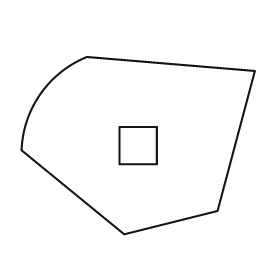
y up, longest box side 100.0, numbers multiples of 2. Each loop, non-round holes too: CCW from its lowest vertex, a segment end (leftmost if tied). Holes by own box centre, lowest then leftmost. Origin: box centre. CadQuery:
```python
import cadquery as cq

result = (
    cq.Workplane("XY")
    .moveTo(-6.0, -38.0)
    .lineTo(34.0, -28.0)
    .lineTo(50.0, 32.0)
    .lineTo(-22.0, 38.0)
    .threePointArc((-42.0, 22.0), (-50.0, -2.0))
    .close()
    .moveTo(-8.0, -8.0)
    .lineTo(8.0, -8.0)
    .lineTo(8.0, 8.0)
    .lineTo(-8.0, 8.0)
    .close()
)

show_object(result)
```